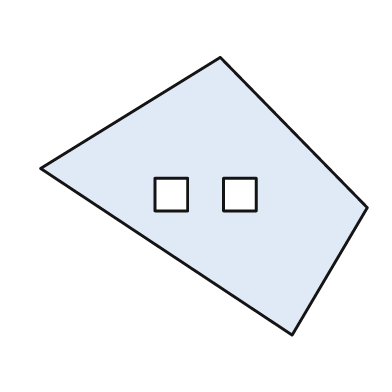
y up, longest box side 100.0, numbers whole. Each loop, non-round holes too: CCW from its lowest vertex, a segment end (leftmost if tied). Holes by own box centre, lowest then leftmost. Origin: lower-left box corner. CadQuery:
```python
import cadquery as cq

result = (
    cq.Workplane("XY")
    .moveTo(77.0, 0.0)
    .lineTo(100.0, 39.0)
    .lineTo(55.0, 85.0)
    .lineTo(0.0, 51.0)
    .close()
    .moveTo(35.0, 38.0)
    .lineTo(45.0, 38.0)
    .lineTo(45.0, 48.0)
    .lineTo(35.0, 48.0)
    .close()
    .moveTo(56.0, 38.0)
    .lineTo(66.0, 38.0)
    .lineTo(66.0, 48.0)
    .lineTo(56.0, 48.0)
    .close()
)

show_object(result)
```